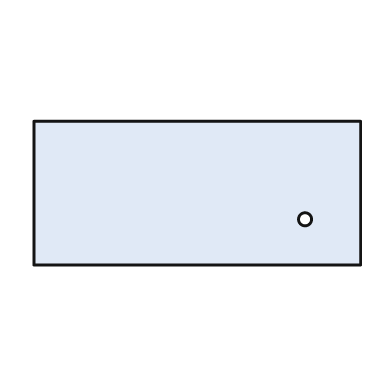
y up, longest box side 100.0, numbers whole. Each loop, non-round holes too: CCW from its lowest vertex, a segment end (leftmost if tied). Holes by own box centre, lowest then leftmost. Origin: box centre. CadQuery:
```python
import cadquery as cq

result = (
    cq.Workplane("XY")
    .moveTo(-50.0, -22.0)
    .lineTo(50.0, -22.0)
    .lineTo(50.0, 22.0)
    .lineTo(-50.0, 22.0)
    .close()
    .moveTo(33.0, -8.0)
    .circle(2.0)
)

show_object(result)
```